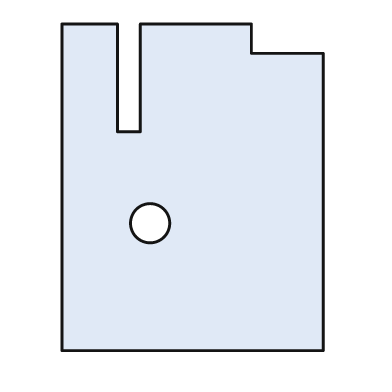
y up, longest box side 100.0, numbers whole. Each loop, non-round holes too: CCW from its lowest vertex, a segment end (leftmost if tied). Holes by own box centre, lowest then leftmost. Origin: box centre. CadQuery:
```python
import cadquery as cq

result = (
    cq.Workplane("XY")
    .moveTo(-40.0, -50.0)
    .lineTo(40.0, -50.0)
    .lineTo(40.0, 41.0)
    .lineTo(18.0, 41.0)
    .lineTo(18.0, 50.0)
    .lineTo(-16.0, 50.0)
    .lineTo(-16.0, 17.0)
    .lineTo(-23.0, 17.0)
    .lineTo(-23.0, 50.0)
    .lineTo(-40.0, 50.0)
    .close()
    .moveTo(-13.0, -11.0)
    .circle(6.0)
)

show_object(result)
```